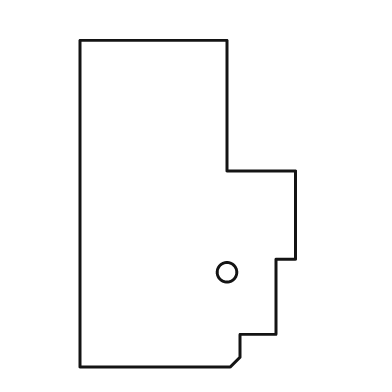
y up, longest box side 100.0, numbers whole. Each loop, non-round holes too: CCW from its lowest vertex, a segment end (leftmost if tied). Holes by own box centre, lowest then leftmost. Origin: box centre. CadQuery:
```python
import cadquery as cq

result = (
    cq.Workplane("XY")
    .moveTo(-33.0, -50.0)
    .lineTo(13.0, -50.0)
    .lineTo(16.0, -47.0)
    .lineTo(16.0, -40.0)
    .lineTo(27.0, -40.0)
    .lineTo(27.0, -17.0)
    .lineTo(33.0, -17.0)
    .lineTo(33.0, 10.0)
    .lineTo(12.0, 10.0)
    .lineTo(12.0, 50.0)
    .lineTo(-33.0, 50.0)
    .close()
    .moveTo(12.0, -21.0)
    .circle(3.0)
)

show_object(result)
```